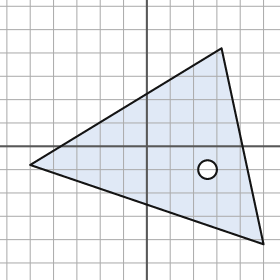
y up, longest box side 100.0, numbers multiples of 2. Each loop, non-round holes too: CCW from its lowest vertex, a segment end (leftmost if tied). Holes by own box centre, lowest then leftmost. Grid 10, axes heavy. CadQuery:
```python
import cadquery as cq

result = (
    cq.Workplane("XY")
    .moveTo(50.0, -42.0)
    .lineTo(32.0, 42.0)
    .lineTo(-50.0, -8.0)
    .close()
    .moveTo(26.0, -10.0)
    .circle(4.0)
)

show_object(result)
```